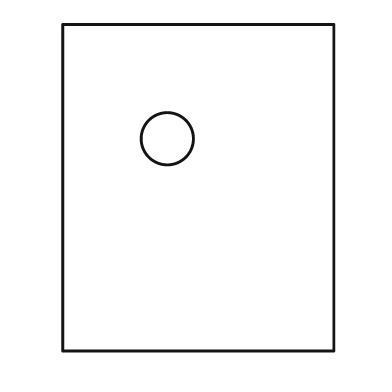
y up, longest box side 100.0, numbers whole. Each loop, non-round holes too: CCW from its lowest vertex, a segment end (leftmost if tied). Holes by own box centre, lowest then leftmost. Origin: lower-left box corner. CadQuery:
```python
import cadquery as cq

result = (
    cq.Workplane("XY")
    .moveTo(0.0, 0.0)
    .lineTo(83.0, 0.0)
    .lineTo(83.0, 100.0)
    .lineTo(0.0, 100.0)
    .close()
    .moveTo(32.0, 65.0)
    .circle(8.0)
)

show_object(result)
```